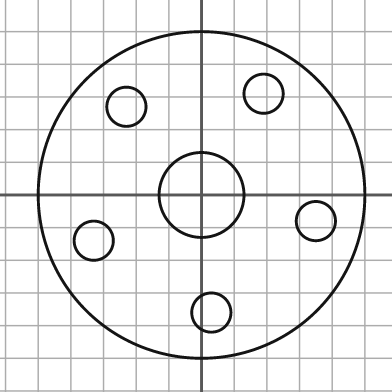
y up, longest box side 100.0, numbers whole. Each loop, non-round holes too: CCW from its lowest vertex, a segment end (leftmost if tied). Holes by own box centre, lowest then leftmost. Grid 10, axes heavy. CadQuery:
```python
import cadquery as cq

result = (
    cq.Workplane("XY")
    .moveTo(0.0, 0.0)
    .circle(50.0)
    .moveTo(3.0, -36.0)
    .circle(6.0)
    .moveTo(-33.0, -14.0)
    .circle(6.0)
    .moveTo(35.0, -8.0)
    .circle(6.0)
    .moveTo(0.0, 0.0)
    .circle(13.0)
    .moveTo(-23.0, 27.0)
    .circle(6.0)
    .moveTo(19.0, 31.0)
    .circle(6.0)
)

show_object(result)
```